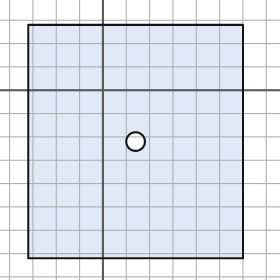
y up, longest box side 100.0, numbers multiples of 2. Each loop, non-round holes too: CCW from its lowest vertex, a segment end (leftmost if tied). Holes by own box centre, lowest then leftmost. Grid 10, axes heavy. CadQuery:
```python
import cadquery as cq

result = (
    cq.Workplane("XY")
    .moveTo(-32.0, -72.0)
    .lineTo(60.0, -72.0)
    .lineTo(60.0, 28.0)
    .lineTo(-32.0, 28.0)
    .close()
    .moveTo(14.0, -22.0)
    .circle(4.0)
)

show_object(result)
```